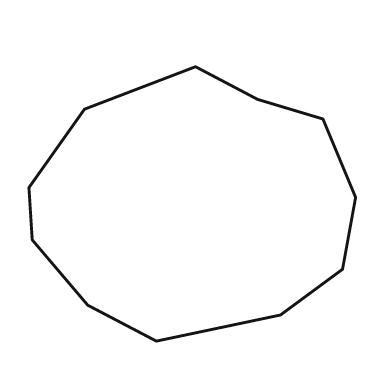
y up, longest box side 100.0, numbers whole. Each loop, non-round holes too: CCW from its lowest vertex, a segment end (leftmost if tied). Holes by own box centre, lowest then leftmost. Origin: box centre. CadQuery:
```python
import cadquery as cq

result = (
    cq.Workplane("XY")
    .moveTo(-11.0, -42.0)
    .lineTo(27.0, -34.0)
    .lineTo(46.0, -20.0)
    .lineTo(50.0, 2.0)
    .lineTo(40.0, 26.0)
    .lineTo(20.0, 32.0)
    .lineTo(1.0, 42.0)
    .lineTo(-33.0, 29.0)
    .lineTo(-50.0, 5.0)
    .lineTo(-49.0, -11.0)
    .lineTo(-32.0, -31.0)
    .close()
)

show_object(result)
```